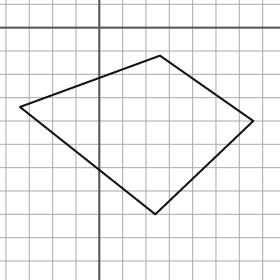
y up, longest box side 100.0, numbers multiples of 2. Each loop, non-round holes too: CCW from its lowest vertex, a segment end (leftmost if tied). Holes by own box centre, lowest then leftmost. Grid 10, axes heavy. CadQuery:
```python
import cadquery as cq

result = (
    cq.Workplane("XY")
    .moveTo(24.0, -80.0)
    .lineTo(66.0, -40.0)
    .lineTo(26.0, -12.0)
    .lineTo(-34.0, -34.0)
    .close()
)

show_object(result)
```